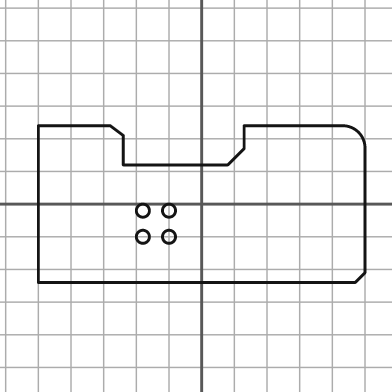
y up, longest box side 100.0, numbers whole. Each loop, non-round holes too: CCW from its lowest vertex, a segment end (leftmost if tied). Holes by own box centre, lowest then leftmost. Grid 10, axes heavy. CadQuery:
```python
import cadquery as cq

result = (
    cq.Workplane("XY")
    .moveTo(-50.0, -24.0)
    .lineTo(47.0, -24.0)
    .lineTo(50.0, -21.0)
    .lineTo(50.0, 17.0)
    .threePointArc((48.0, 22.0), (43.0, 24.0))
    .lineTo(13.0, 24.0)
    .lineTo(13.0, 17.0)
    .lineTo(8.0, 12.0)
    .lineTo(-24.0, 12.0)
    .lineTo(-24.0, 21.0)
    .lineTo(-28.0, 24.0)
    .lineTo(-50.0, 24.0)
    .close()
    .moveTo(-18.0, -10.0)
    .circle(2.0)
    .moveTo(-10.0, -10.0)
    .circle(2.0)
    .moveTo(-18.0, -2.0)
    .circle(2.0)
    .moveTo(-10.0, -2.0)
    .circle(2.0)
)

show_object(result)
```